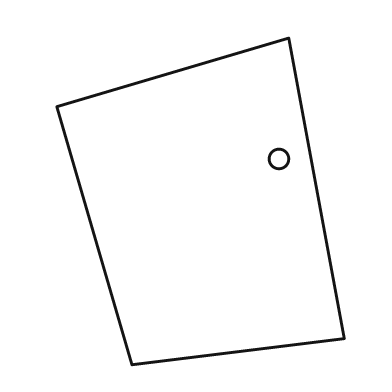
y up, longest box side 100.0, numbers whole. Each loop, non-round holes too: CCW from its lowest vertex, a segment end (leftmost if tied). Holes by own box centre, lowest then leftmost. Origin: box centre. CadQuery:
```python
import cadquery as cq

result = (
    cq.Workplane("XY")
    .moveTo(-21.0, -50.0)
    .lineTo(44.0, -42.0)
    .lineTo(27.0, 50.0)
    .lineTo(-44.0, 29.0)
    .close()
    .moveTo(24.0, 13.0)
    .circle(3.0)
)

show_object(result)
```